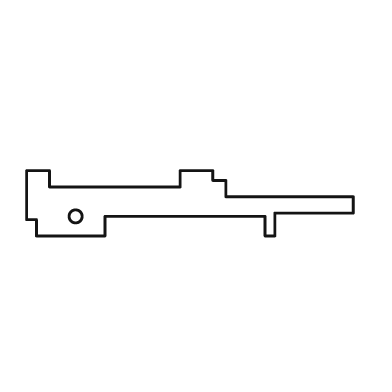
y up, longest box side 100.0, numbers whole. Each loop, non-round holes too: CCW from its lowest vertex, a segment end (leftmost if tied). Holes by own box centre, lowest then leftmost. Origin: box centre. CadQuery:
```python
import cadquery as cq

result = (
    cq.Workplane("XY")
    .moveTo(-47.0, -10.0)
    .lineTo(-26.0, -10.0)
    .lineTo(-26.0, -4.0)
    .lineTo(23.0, -4.0)
    .lineTo(23.0, -10.0)
    .lineTo(26.0, -10.0)
    .lineTo(26.0, -3.0)
    .lineTo(50.0, -3.0)
    .lineTo(50.0, 2.0)
    .lineTo(11.0, 2.0)
    .lineTo(11.0, 7.0)
    .lineTo(7.0, 7.0)
    .lineTo(7.0, 10.0)
    .lineTo(-3.0, 10.0)
    .lineTo(-3.0, 5.0)
    .lineTo(-43.0, 5.0)
    .lineTo(-43.0, 10.0)
    .lineTo(-50.0, 10.0)
    .lineTo(-50.0, -5.0)
    .lineTo(-47.0, -5.0)
    .close()
    .moveTo(-35.0, -4.0)
    .circle(2.0)
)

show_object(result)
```